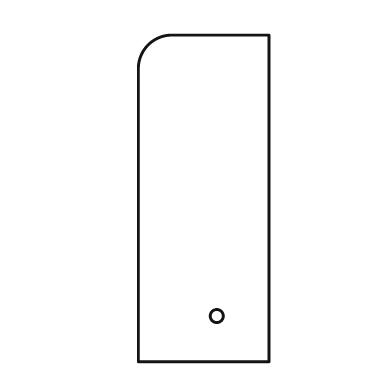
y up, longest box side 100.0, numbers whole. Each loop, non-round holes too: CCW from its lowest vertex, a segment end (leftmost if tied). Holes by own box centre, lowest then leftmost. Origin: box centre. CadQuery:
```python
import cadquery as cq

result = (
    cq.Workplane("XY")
    .moveTo(-20.0, -50.0)
    .lineTo(20.0, -50.0)
    .lineTo(20.0, 50.0)
    .lineTo(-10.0, 50.0)
    .threePointArc((-17.0, 47.0), (-20.0, 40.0))
    .close()
    .moveTo(4.0, -36.0)
    .circle(2.0)
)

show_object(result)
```